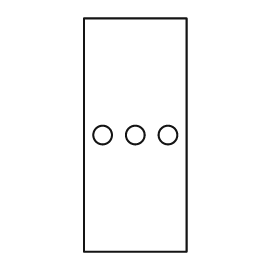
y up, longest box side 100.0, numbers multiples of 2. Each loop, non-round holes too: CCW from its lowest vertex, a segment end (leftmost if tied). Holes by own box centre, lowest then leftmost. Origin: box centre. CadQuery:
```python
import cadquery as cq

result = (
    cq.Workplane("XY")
    .moveTo(-22.0, -50.0)
    .lineTo(22.0, -50.0)
    .lineTo(22.0, 50.0)
    .lineTo(-22.0, 50.0)
    .close()
    .moveTo(-14.0, 0.0)
    .circle(4.0)
    .moveTo(0.0, 0.0)
    .circle(4.0)
    .moveTo(14.0, 0.0)
    .circle(4.0)
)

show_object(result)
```